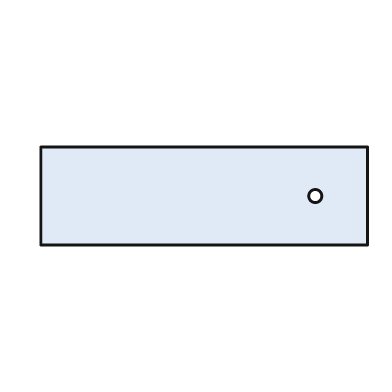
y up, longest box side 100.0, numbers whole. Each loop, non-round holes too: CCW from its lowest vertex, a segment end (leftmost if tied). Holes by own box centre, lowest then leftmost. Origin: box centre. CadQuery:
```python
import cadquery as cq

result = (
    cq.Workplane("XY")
    .moveTo(-50.0, -15.0)
    .lineTo(50.0, -15.0)
    .lineTo(50.0, 15.0)
    .lineTo(-50.0, 15.0)
    .close()
    .moveTo(34.0, 0.0)
    .circle(2.0)
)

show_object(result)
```